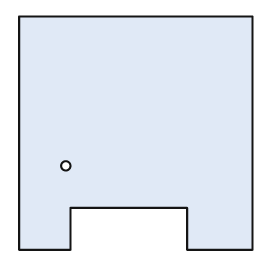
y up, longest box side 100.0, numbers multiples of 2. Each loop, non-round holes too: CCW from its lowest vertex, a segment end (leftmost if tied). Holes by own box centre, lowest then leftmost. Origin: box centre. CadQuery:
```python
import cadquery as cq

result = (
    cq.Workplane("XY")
    .moveTo(-50.0, -50.0)
    .lineTo(-28.0, -50.0)
    .lineTo(-28.0, -32.0)
    .lineTo(22.0, -32.0)
    .lineTo(22.0, -50.0)
    .lineTo(50.0, -50.0)
    .lineTo(50.0, 50.0)
    .lineTo(-50.0, 50.0)
    .close()
    .moveTo(-30.0, -14.0)
    .circle(2.0)
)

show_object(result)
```